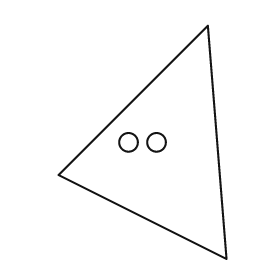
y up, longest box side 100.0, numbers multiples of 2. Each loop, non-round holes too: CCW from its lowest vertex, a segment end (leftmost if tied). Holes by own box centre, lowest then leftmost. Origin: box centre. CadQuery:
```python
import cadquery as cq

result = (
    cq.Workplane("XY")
    .moveTo(36.0, -50.0)
    .lineTo(28.0, 50.0)
    .lineTo(-36.0, -14.0)
    .close()
    .moveTo(-6.0, 0.0)
    .circle(4.0)
    .moveTo(6.0, 0.0)
    .circle(4.0)
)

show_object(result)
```